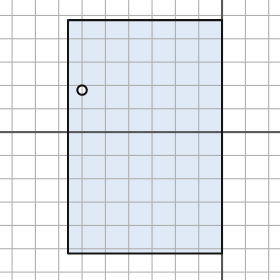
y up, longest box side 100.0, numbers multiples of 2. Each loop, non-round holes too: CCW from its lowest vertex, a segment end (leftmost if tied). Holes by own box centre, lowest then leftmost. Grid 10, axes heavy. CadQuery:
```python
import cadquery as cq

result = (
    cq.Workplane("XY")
    .moveTo(-66.0, -52.0)
    .lineTo(0.0, -52.0)
    .lineTo(0.0, 48.0)
    .lineTo(-66.0, 48.0)
    .close()
    .moveTo(-60.0, 18.0)
    .circle(2.0)
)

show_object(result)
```